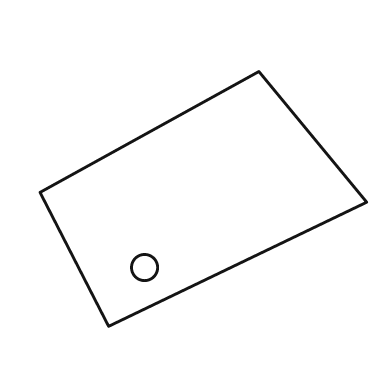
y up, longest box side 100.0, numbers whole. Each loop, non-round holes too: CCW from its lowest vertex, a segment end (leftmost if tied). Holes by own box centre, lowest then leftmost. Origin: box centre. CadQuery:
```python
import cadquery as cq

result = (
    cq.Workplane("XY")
    .moveTo(-29.0, -39.0)
    .lineTo(50.0, -1.0)
    .lineTo(17.0, 39.0)
    .lineTo(-50.0, 2.0)
    .close()
    .moveTo(-18.0, -21.0)
    .circle(4.0)
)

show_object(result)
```